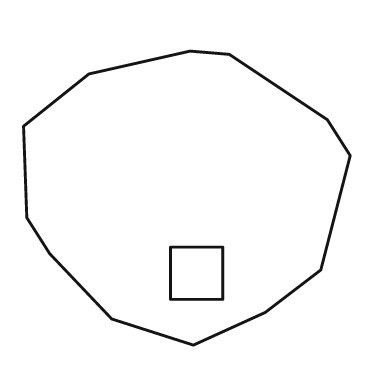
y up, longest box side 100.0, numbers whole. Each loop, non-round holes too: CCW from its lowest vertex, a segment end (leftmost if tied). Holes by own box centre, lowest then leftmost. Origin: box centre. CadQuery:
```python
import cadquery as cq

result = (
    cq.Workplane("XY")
    .moveTo(2.0, -45.0)
    .lineTo(24.0, -35.0)
    .lineTo(41.0, -22.0)
    .lineTo(50.0, 13.0)
    .lineTo(43.0, 24.0)
    .lineTo(13.0, 44.0)
    .lineTo(1.0, 45.0)
    .lineTo(-30.0, 38.0)
    .lineTo(-50.0, 22.0)
    .lineTo(-49.0, -6.0)
    .lineTo(-42.0, -17.0)
    .lineTo(-23.0, -37.0)
    .close()
    .moveTo(-5.0, -31.0)
    .lineTo(11.0, -31.0)
    .lineTo(11.0, -15.0)
    .lineTo(-5.0, -15.0)
    .close()
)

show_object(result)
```